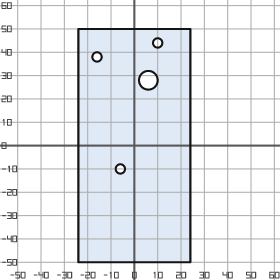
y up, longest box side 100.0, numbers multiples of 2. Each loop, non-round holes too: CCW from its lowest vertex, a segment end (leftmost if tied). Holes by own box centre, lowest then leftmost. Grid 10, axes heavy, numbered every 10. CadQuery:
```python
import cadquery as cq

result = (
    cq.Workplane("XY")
    .moveTo(-24.0, -50.0)
    .lineTo(24.0, -50.0)
    .lineTo(24.0, 50.0)
    .lineTo(-24.0, 50.0)
    .close()
    .moveTo(-6.0, -10.0)
    .circle(2.0)
    .moveTo(6.0, 28.0)
    .circle(4.0)
    .moveTo(-16.0, 38.0)
    .circle(2.0)
    .moveTo(10.0, 44.0)
    .circle(2.0)
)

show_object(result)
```